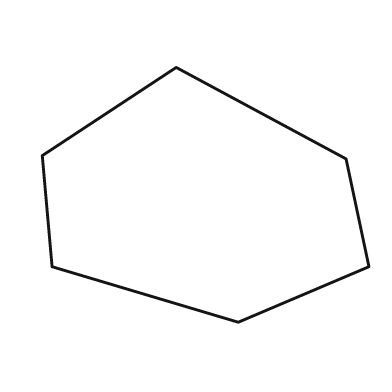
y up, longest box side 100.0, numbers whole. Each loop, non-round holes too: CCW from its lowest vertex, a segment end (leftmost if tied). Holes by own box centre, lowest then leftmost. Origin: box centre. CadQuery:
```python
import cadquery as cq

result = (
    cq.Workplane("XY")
    .moveTo(10.0, -39.0)
    .lineTo(50.0, -22.0)
    .lineTo(43.0, 11.0)
    .lineTo(-9.0, 39.0)
    .lineTo(-50.0, 12.0)
    .lineTo(-47.0, -22.0)
    .close()
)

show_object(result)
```